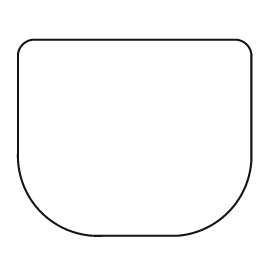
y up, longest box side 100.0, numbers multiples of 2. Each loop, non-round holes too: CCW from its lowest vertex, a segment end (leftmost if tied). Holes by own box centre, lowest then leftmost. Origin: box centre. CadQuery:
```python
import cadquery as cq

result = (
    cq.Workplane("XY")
    .moveTo(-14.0, -42.0)
    .lineTo(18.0, -42.0)
    .threePointArc((40.0, -32.0), (50.0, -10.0))
    .lineTo(50.0, 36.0)
    .threePointArc((48.0, 40.0), (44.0, 42.0))
    .lineTo(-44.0, 42.0)
    .threePointArc((-48.0, 40.0), (-50.0, 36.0))
    .lineTo(-50.0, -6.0)
    .threePointArc((-40.0, -32.0), (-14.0, -42.0))
    .close()
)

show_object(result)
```